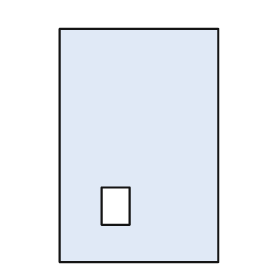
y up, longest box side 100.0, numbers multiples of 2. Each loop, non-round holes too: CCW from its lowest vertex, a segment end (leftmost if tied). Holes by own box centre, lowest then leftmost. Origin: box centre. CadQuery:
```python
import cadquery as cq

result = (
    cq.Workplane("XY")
    .moveTo(-34.0, -50.0)
    .lineTo(34.0, -50.0)
    .lineTo(34.0, 50.0)
    .lineTo(-34.0, 50.0)
    .close()
    .moveTo(-16.0, -34.0)
    .lineTo(-4.0, -34.0)
    .lineTo(-4.0, -18.0)
    .lineTo(-16.0, -18.0)
    .close()
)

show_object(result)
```